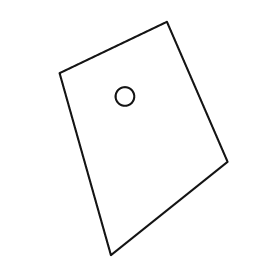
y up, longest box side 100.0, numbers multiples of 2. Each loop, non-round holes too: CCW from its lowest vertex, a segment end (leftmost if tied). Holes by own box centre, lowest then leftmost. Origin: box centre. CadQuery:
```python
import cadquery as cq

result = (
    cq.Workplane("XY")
    .moveTo(-14.0, -50.0)
    .lineTo(36.0, -10.0)
    .lineTo(10.0, 50.0)
    .lineTo(-36.0, 28.0)
    .close()
    .moveTo(-8.0, 18.0)
    .circle(4.0)
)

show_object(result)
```